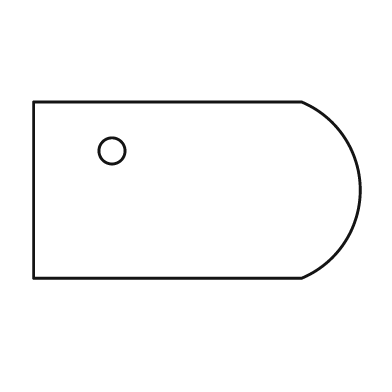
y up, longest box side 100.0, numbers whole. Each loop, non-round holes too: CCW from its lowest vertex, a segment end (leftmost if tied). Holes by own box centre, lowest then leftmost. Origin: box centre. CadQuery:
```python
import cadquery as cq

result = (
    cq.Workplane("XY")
    .moveTo(-50.0, -27.0)
    .lineTo(32.0, -27.0)
    .threePointArc((50.0, 0.0), (32.0, 27.0))
    .lineTo(-50.0, 27.0)
    .close()
    .moveTo(-26.0, 12.0)
    .circle(4.0)
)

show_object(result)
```